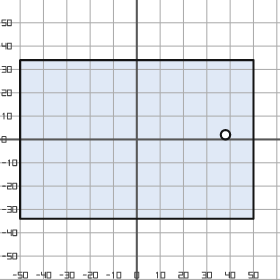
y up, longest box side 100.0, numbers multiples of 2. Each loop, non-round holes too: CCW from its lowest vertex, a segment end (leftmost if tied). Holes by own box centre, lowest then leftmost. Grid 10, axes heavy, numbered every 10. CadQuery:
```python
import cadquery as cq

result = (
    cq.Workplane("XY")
    .moveTo(-50.0, -34.0)
    .lineTo(50.0, -34.0)
    .lineTo(50.0, 34.0)
    .lineTo(-50.0, 34.0)
    .close()
    .moveTo(38.0, 2.0)
    .circle(2.0)
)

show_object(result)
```